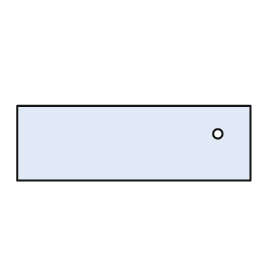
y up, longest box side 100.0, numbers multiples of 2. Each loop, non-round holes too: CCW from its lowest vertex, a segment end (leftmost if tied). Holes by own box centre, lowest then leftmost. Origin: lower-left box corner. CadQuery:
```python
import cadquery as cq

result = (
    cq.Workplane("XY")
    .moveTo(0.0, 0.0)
    .lineTo(100.0, 0.0)
    .lineTo(100.0, 32.0)
    .lineTo(0.0, 32.0)
    .close()
    .moveTo(86.0, 20.0)
    .circle(2.0)
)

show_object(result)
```